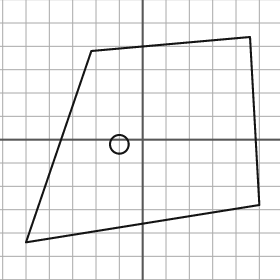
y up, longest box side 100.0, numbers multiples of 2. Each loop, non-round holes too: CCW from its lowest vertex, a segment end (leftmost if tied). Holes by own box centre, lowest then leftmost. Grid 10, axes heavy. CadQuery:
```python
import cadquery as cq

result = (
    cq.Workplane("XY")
    .moveTo(-50.0, -44.0)
    .lineTo(50.0, -28.0)
    .lineTo(46.0, 44.0)
    .lineTo(-22.0, 38.0)
    .close()
    .moveTo(-10.0, -2.0)
    .circle(4.0)
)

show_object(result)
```